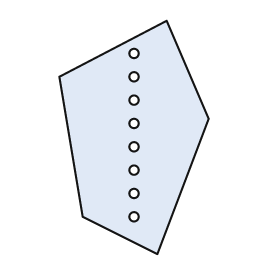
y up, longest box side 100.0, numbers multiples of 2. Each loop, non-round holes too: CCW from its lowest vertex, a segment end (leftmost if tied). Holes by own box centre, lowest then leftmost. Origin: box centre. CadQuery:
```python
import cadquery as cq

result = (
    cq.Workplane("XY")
    .moveTo(10.0, -50.0)
    .lineTo(32.0, 8.0)
    .lineTo(14.0, 50.0)
    .lineTo(-32.0, 26.0)
    .lineTo(-22.0, -34.0)
    .close()
    .moveTo(0.0, -34.0)
    .circle(2.0)
    .moveTo(0.0, -24.0)
    .circle(2.0)
    .moveTo(0.0, -14.0)
    .circle(2.0)
    .moveTo(0.0, -4.0)
    .circle(2.0)
    .moveTo(0.0, 6.0)
    .circle(2.0)
    .moveTo(0.0, 16.0)
    .circle(2.0)
    .moveTo(0.0, 26.0)
    .circle(2.0)
    .moveTo(0.0, 36.0)
    .circle(2.0)
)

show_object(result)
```